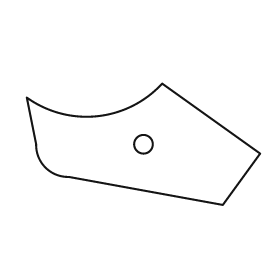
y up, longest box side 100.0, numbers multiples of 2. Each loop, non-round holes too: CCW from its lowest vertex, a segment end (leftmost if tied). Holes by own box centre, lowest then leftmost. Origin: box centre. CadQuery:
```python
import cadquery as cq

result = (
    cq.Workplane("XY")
    .moveTo(34.0, -26.0)
    .lineTo(50.0, -4.0)
    .lineTo(8.0, 26.0)
    .threePointArc((-20.0, 12.0), (-50.0, 20.0))
    .lineTo(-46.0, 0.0)
    .threePointArc((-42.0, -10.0), (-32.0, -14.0))
    .close()
    .moveTo(0.0, 0.0)
    .circle(4.0)
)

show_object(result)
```